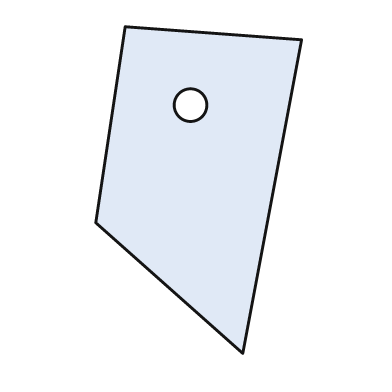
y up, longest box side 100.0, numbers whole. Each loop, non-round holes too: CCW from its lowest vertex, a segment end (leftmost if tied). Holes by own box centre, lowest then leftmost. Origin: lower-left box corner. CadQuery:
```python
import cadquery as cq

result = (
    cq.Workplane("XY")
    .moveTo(45.0, 0.0)
    .lineTo(63.0, 96.0)
    .lineTo(9.0, 100.0)
    .lineTo(0.0, 40.0)
    .close()
    .moveTo(29.0, 76.0)
    .circle(5.0)
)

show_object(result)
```